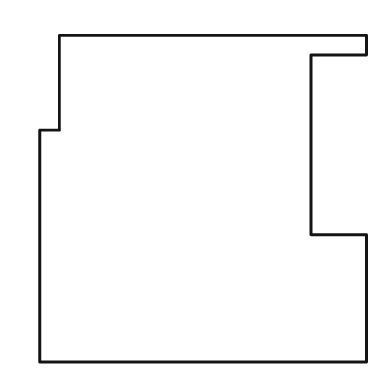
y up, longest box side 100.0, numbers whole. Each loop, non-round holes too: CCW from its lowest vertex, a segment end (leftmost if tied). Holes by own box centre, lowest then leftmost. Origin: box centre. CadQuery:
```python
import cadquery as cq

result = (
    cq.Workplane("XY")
    .moveTo(-50.0, -50.0)
    .lineTo(50.0, -50.0)
    .lineTo(50.0, -11.0)
    .lineTo(33.0, -11.0)
    .lineTo(33.0, 44.0)
    .lineTo(50.0, 44.0)
    .lineTo(50.0, 50.0)
    .lineTo(-44.0, 50.0)
    .lineTo(-44.0, 21.0)
    .lineTo(-50.0, 21.0)
    .close()
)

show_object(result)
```